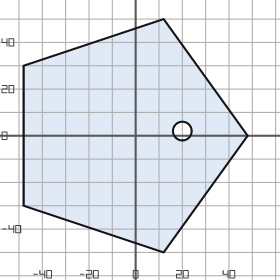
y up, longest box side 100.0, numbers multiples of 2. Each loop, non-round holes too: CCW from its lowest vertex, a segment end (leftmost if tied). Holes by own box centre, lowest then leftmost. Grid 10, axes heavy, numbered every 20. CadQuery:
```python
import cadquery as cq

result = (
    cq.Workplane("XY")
    .moveTo(12.0, -50.0)
    .lineTo(48.0, 0.0)
    .lineTo(12.0, 50.0)
    .lineTo(-48.0, 30.0)
    .lineTo(-48.0, -30.0)
    .close()
    .moveTo(20.0, 2.0)
    .circle(4.0)
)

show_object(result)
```